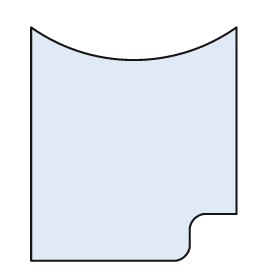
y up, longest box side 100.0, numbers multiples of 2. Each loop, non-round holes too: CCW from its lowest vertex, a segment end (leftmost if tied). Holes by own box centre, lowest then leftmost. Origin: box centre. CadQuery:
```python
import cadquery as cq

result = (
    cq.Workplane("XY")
    .moveTo(-44.0, -50.0)
    .lineTo(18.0, -50.0)
    .threePointArc((22.0, -48.0), (24.0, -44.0))
    .lineTo(24.0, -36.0)
    .threePointArc((26.0, -32.0), (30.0, -30.0))
    .lineTo(44.0, -30.0)
    .lineTo(44.0, 50.0)
    .threePointArc((0.0, 36.0), (-44.0, 50.0))
    .close()
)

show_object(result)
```